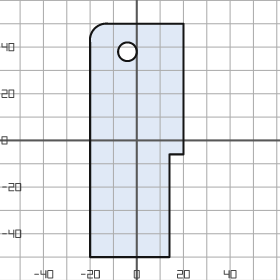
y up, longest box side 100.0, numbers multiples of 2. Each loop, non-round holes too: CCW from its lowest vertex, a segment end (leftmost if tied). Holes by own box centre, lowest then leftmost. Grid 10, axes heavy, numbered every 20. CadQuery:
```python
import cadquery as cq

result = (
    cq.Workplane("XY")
    .moveTo(-20.0, -50.0)
    .lineTo(14.0, -50.0)
    .lineTo(14.0, -6.0)
    .lineTo(20.0, -6.0)
    .lineTo(20.0, 50.0)
    .lineTo(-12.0, 50.0)
    .threePointArc((-18.0, 48.0), (-20.0, 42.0))
    .close()
    .moveTo(-4.0, 38.0)
    .circle(4.0)
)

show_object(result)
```